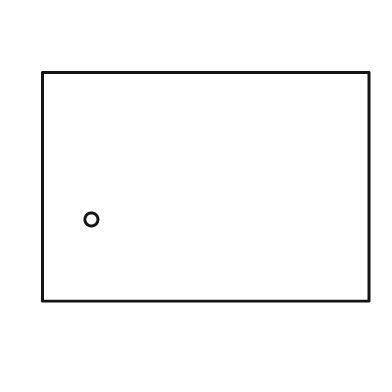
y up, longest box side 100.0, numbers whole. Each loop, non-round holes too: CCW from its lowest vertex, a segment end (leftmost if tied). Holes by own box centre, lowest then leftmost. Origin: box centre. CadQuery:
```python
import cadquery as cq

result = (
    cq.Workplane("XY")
    .moveTo(-50.0, -35.0)
    .lineTo(50.0, -35.0)
    .lineTo(50.0, 35.0)
    .lineTo(-50.0, 35.0)
    .close()
    .moveTo(-35.0, -10.0)
    .circle(2.0)
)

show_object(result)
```